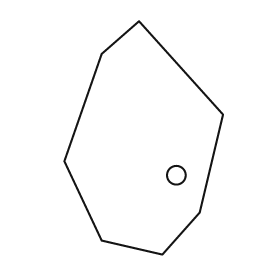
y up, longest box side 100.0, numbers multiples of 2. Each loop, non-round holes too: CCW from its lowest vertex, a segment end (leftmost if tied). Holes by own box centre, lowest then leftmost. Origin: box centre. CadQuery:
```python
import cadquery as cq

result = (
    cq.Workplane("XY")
    .moveTo(8.0, -50.0)
    .lineTo(24.0, -32.0)
    .lineTo(34.0, 10.0)
    .lineTo(-2.0, 50.0)
    .lineTo(-18.0, 36.0)
    .lineTo(-34.0, -10.0)
    .lineTo(-18.0, -44.0)
    .close()
    .moveTo(14.0, -16.0)
    .circle(4.0)
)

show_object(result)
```